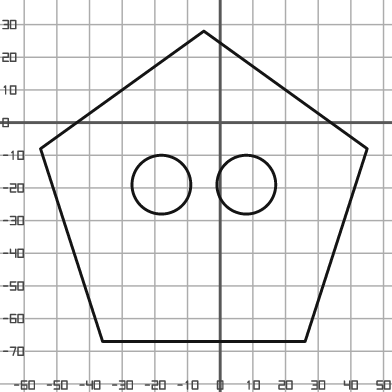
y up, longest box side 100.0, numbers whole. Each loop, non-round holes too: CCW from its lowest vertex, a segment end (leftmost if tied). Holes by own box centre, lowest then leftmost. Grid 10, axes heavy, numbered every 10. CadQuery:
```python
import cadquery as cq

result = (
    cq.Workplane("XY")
    .moveTo(-36.0, -67.0)
    .lineTo(26.0, -67.0)
    .lineTo(45.0, -8.0)
    .lineTo(-5.0, 28.0)
    .lineTo(-55.0, -8.0)
    .close()
    .moveTo(-18.0, -19.0)
    .circle(9.0)
    .moveTo(8.0, -19.0)
    .circle(9.0)
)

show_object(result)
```